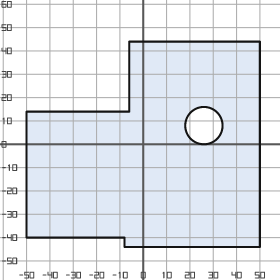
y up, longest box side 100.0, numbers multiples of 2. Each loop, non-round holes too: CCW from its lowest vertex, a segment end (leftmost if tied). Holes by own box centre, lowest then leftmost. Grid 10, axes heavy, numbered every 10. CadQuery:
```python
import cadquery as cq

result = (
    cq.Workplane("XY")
    .moveTo(-8.0, -44.0)
    .lineTo(50.0, -44.0)
    .lineTo(50.0, 44.0)
    .lineTo(-6.0, 44.0)
    .lineTo(-6.0, 14.0)
    .lineTo(-50.0, 14.0)
    .lineTo(-50.0, -40.0)
    .lineTo(-8.0, -40.0)
    .close()
    .moveTo(26.0, 8.0)
    .circle(8.0)
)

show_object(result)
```